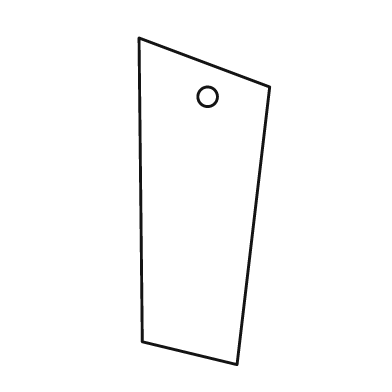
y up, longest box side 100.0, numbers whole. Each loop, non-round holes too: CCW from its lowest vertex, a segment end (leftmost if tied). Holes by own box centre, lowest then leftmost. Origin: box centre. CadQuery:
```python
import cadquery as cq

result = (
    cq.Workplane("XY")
    .moveTo(10.0, -50.0)
    .lineTo(20.0, 35.0)
    .lineTo(-20.0, 50.0)
    .lineTo(-19.0, -43.0)
    .close()
    .moveTo(1.0, 32.0)
    .circle(3.0)
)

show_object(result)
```